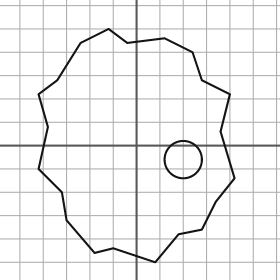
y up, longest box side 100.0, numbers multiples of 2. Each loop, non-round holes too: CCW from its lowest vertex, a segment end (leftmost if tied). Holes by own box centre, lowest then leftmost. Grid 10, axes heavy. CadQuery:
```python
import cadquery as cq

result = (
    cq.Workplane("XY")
    .moveTo(8.0, -50.0)
    .lineTo(18.0, -38.0)
    .lineTo(28.0, -36.0)
    .lineTo(34.0, -24.0)
    .lineTo(42.0, -14.0)
    .lineTo(36.0, 6.0)
    .lineTo(40.0, 22.0)
    .lineTo(28.0, 28.0)
    .lineTo(24.0, 40.0)
    .lineTo(12.0, 46.0)
    .lineTo(-4.0, 44.0)
    .lineTo(-12.0, 50.0)
    .lineTo(-24.0, 44.0)
    .lineTo(-34.0, 28.0)
    .lineTo(-42.0, 22.0)
    .lineTo(-38.0, 8.0)
    .lineTo(-42.0, -10.0)
    .lineTo(-32.0, -20.0)
    .lineTo(-30.0, -32.0)
    .lineTo(-18.0, -46.0)
    .lineTo(-10.0, -44.0)
    .close()
    .moveTo(20.0, -6.0)
    .circle(8.0)
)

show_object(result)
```